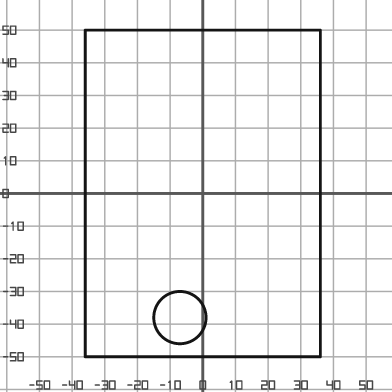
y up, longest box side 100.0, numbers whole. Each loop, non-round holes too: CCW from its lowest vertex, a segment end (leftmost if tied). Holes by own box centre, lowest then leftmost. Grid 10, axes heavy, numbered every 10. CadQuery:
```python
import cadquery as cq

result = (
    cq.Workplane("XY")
    .moveTo(-36.0, -50.0)
    .lineTo(36.0, -50.0)
    .lineTo(36.0, 50.0)
    .lineTo(-36.0, 50.0)
    .close()
    .moveTo(-7.0, -38.0)
    .circle(8.0)
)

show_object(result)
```